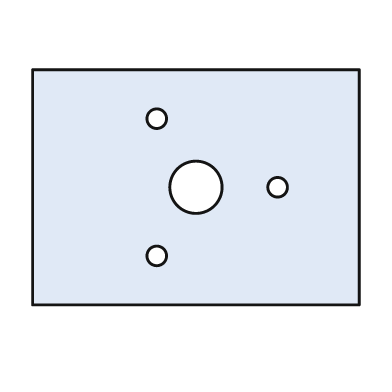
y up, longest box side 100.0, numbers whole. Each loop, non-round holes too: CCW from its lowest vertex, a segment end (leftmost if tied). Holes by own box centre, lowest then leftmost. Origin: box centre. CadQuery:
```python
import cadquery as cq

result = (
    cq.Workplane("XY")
    .moveTo(-50.0, -36.0)
    .lineTo(50.0, -36.0)
    .lineTo(50.0, 36.0)
    .lineTo(-50.0, 36.0)
    .close()
    .moveTo(-12.0, -21.0)
    .circle(3.0)
    .moveTo(0.0, 0.0)
    .circle(8.0)
    .moveTo(25.0, 0.0)
    .circle(3.0)
    .moveTo(-12.0, 21.0)
    .circle(3.0)
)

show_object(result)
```